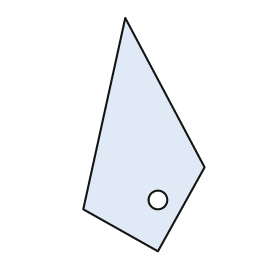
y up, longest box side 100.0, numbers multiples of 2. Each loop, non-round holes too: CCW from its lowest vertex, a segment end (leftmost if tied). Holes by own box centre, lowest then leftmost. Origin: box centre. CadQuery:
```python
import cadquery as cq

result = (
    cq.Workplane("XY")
    .moveTo(6.0, -50.0)
    .lineTo(26.0, -14.0)
    .lineTo(-8.0, 50.0)
    .lineTo(-26.0, -32.0)
    .close()
    .moveTo(6.0, -28.0)
    .circle(4.0)
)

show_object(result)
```